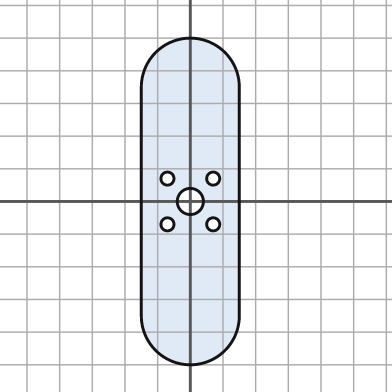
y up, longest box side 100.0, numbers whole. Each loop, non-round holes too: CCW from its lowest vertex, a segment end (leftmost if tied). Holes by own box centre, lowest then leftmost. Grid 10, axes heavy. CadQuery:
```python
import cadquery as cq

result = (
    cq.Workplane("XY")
    .moveTo(-15.0, -35.0)
    .threePointArc((0.0, -50.0), (15.0, -35.0))
    .lineTo(15.0, 35.0)
    .threePointArc((0.0, 50.0), (-15.0, 35.0))
    .close()
    .moveTo(-7.0, -7.0)
    .circle(2.0)
    .moveTo(7.0, -7.0)
    .circle(2.0)
    .moveTo(0.0, 0.0)
    .circle(4.0)
    .moveTo(-7.0, 7.0)
    .circle(2.0)
    .moveTo(7.0, 7.0)
    .circle(2.0)
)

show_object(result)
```